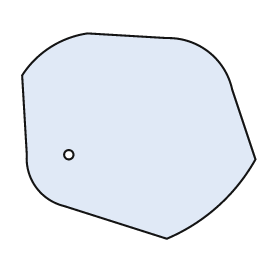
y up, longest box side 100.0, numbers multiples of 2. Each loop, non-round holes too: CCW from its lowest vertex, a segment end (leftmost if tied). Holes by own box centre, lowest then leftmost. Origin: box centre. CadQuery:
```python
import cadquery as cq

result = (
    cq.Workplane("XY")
    .moveTo(12.0, -44.0)
    .threePointArc((34.0, -30.0), (50.0, -10.0))
    .lineTo(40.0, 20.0)
    .threePointArc((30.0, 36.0), (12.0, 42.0))
    .lineTo(-22.0, 44.0)
    .threePointArc((-38.0, 38.0), (-50.0, 26.0))
    .lineTo(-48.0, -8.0)
    .threePointArc((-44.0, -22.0), (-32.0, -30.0))
    .close()
    .moveTo(-30.0, -8.0)
    .circle(2.0)
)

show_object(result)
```